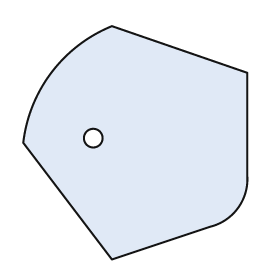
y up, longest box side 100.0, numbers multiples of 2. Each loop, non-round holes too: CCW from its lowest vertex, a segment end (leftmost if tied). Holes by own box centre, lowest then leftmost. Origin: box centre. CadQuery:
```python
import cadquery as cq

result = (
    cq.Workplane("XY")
    .moveTo(-10.0, -50.0)
    .lineTo(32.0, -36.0)
    .threePointArc((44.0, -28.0), (48.0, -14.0))
    .lineTo(48.0, 30.0)
    .lineTo(-10.0, 50.0)
    .threePointArc((-36.0, 30.0), (-48.0, 0.0))
    .close()
    .moveTo(-18.0, 2.0)
    .circle(4.0)
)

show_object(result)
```